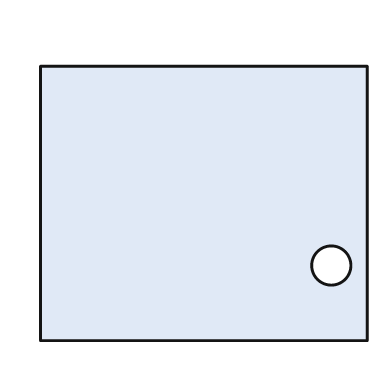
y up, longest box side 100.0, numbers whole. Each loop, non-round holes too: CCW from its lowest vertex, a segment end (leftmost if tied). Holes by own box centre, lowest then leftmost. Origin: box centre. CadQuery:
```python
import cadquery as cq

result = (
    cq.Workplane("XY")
    .moveTo(-50.0, -42.0)
    .lineTo(50.0, -42.0)
    .lineTo(50.0, 42.0)
    .lineTo(-50.0, 42.0)
    .close()
    .moveTo(39.0, -19.0)
    .circle(6.0)
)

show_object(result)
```